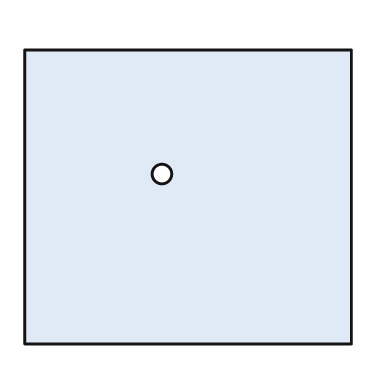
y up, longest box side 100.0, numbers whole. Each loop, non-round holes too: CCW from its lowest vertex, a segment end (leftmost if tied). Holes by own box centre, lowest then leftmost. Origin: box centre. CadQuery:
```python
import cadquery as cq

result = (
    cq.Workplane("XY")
    .moveTo(-50.0, -45.0)
    .lineTo(50.0, -45.0)
    .lineTo(50.0, 45.0)
    .lineTo(-50.0, 45.0)
    .close()
    .moveTo(-8.0, 7.0)
    .circle(3.0)
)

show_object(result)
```